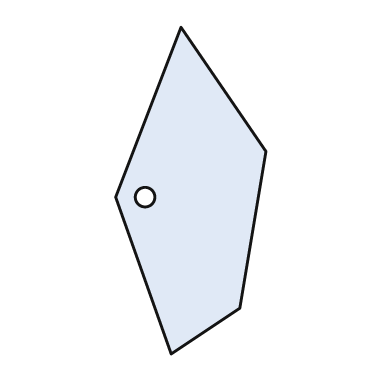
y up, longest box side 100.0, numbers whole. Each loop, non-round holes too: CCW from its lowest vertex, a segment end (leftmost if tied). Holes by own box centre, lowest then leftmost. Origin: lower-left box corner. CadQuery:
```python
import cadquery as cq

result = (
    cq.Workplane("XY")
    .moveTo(17.0, 0.0)
    .lineTo(38.0, 14.0)
    .lineTo(46.0, 62.0)
    .lineTo(20.0, 100.0)
    .lineTo(0.0, 48.0)
    .close()
    .moveTo(9.0, 48.0)
    .circle(3.0)
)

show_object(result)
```